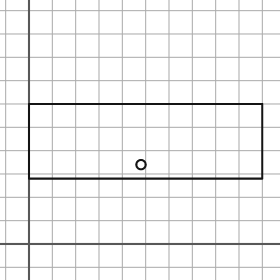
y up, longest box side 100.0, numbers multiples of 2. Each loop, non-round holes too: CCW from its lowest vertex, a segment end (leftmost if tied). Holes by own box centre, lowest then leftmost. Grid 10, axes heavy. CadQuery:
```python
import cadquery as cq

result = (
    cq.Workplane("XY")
    .moveTo(0.0, 28.0)
    .lineTo(100.0, 28.0)
    .lineTo(100.0, 60.0)
    .lineTo(0.0, 60.0)
    .close()
    .moveTo(48.0, 34.0)
    .circle(2.0)
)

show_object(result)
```